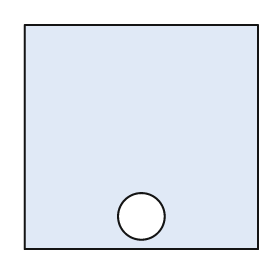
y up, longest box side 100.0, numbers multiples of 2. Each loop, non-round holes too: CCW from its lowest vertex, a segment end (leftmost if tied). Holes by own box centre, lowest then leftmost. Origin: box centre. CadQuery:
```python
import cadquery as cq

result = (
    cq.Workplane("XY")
    .moveTo(-50.0, -48.0)
    .lineTo(50.0, -48.0)
    .lineTo(50.0, 48.0)
    .lineTo(-50.0, 48.0)
    .close()
    .moveTo(0.0, -34.0)
    .circle(10.0)
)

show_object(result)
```